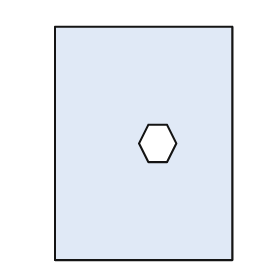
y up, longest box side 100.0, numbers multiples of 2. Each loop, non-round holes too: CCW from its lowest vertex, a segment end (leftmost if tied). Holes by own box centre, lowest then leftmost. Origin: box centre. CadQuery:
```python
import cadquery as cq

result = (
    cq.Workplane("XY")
    .moveTo(-38.0, -50.0)
    .lineTo(38.0, -50.0)
    .lineTo(38.0, 50.0)
    .lineTo(-38.0, 50.0)
    .close()
    .moveTo(2.0, -8.0)
    .lineTo(10.0, -8.0)
    .lineTo(14.0, 0.0)
    .lineTo(10.0, 8.0)
    .lineTo(2.0, 8.0)
    .lineTo(-2.0, 0.0)
    .close()
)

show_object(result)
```